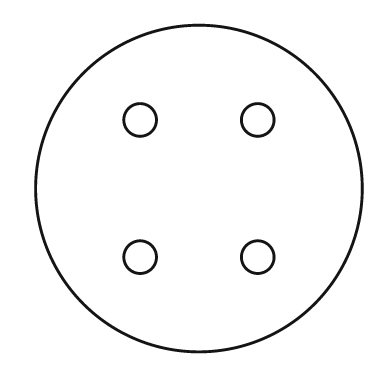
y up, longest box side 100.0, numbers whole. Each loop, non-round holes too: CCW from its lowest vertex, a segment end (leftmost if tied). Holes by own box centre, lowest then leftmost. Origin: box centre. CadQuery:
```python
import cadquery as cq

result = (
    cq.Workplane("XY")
    .moveTo(0.0, 0.0)
    .circle(50.0)
    .moveTo(-18.0, -21.0)
    .circle(5.0)
    .moveTo(18.0, -21.0)
    .circle(5.0)
    .moveTo(-18.0, 21.0)
    .circle(5.0)
    .moveTo(18.0, 21.0)
    .circle(5.0)
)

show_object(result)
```